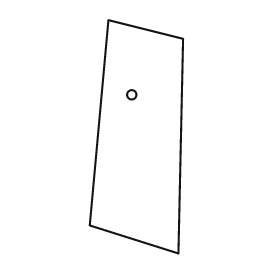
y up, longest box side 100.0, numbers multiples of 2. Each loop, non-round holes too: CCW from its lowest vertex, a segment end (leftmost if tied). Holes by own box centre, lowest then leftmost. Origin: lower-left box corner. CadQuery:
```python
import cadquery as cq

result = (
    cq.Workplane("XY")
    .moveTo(38.0, 0.0)
    .lineTo(40.0, 92.0)
    .lineTo(8.0, 100.0)
    .lineTo(0.0, 12.0)
    .close()
    .moveTo(18.0, 68.0)
    .circle(2.0)
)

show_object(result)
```